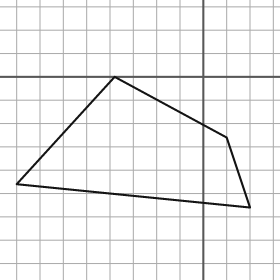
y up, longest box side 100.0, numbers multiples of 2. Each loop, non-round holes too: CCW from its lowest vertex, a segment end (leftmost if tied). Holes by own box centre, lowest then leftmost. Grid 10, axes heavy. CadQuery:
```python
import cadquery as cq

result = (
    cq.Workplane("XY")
    .moveTo(20.0, -56.0)
    .lineTo(10.0, -26.0)
    .lineTo(-38.0, 0.0)
    .lineTo(-80.0, -46.0)
    .close()
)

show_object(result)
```